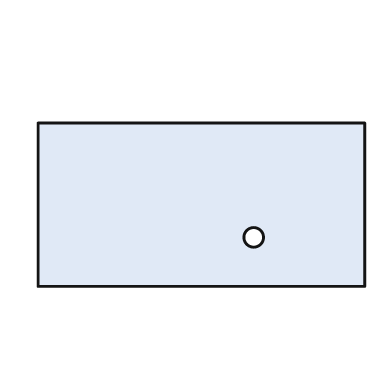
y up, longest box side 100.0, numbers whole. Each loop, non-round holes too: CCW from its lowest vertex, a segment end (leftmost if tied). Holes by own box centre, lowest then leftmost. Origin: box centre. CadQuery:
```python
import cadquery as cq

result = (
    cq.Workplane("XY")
    .moveTo(-50.0, -25.0)
    .lineTo(50.0, -25.0)
    .lineTo(50.0, 25.0)
    .lineTo(-50.0, 25.0)
    .close()
    .moveTo(16.0, -10.0)
    .circle(3.0)
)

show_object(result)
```